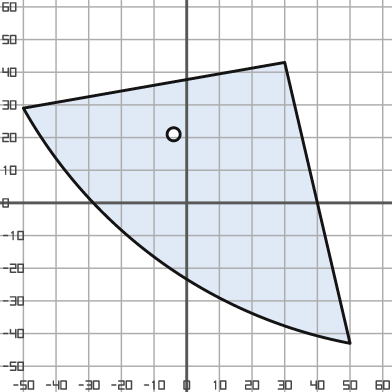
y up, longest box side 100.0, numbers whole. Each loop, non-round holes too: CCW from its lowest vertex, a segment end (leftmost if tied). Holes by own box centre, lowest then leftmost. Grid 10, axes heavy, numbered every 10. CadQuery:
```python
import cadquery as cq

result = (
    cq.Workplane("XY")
    .moveTo(50.0, -43.0)
    .lineTo(30.0, 43.0)
    .lineTo(-50.0, 29.0)
    .threePointArc((-8.0, -18.0), (50.0, -43.0))
    .close()
    .moveTo(-4.0, 21.0)
    .circle(2.0)
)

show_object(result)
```